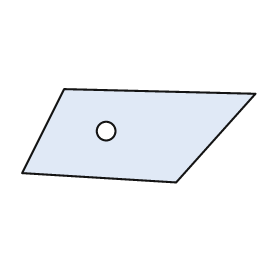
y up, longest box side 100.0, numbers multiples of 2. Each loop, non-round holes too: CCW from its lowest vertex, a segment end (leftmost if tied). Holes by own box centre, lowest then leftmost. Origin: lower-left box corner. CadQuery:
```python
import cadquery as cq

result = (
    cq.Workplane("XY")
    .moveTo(66.0, 0.0)
    .lineTo(100.0, 38.0)
    .lineTo(18.0, 40.0)
    .lineTo(0.0, 4.0)
    .close()
    .moveTo(36.0, 22.0)
    .circle(4.0)
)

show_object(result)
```